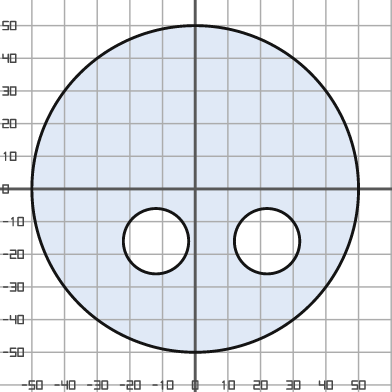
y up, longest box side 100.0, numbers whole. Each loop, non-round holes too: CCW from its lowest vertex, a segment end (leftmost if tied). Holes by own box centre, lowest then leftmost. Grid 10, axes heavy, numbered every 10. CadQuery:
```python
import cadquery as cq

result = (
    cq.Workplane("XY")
    .moveTo(0.0, 0.0)
    .circle(50.0)
    .moveTo(-12.0, -16.0)
    .circle(10.0)
    .moveTo(22.0, -16.0)
    .circle(10.0)
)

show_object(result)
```